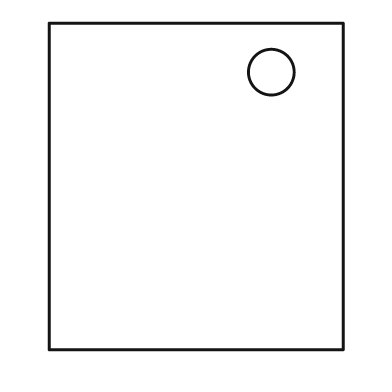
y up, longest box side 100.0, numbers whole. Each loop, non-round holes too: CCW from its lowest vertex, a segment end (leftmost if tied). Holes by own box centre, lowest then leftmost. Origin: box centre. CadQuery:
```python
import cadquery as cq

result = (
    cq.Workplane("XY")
    .moveTo(-45.0, -50.0)
    .lineTo(45.0, -50.0)
    .lineTo(45.0, 50.0)
    .lineTo(-45.0, 50.0)
    .close()
    .moveTo(23.0, 35.0)
    .circle(7.0)
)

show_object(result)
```